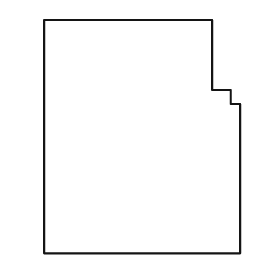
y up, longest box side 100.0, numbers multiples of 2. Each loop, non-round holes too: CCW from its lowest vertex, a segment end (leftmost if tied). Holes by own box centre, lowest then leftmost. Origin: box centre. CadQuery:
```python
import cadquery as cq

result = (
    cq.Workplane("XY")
    .moveTo(-42.0, -50.0)
    .lineTo(42.0, -50.0)
    .lineTo(42.0, 14.0)
    .lineTo(38.0, 14.0)
    .lineTo(38.0, 20.0)
    .lineTo(30.0, 20.0)
    .lineTo(30.0, 50.0)
    .lineTo(-42.0, 50.0)
    .close()
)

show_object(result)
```